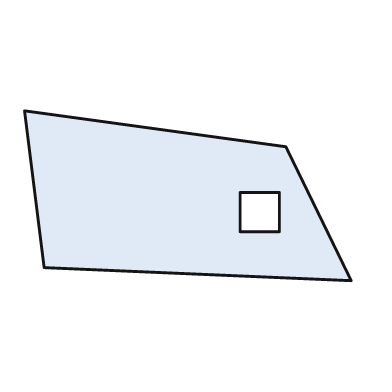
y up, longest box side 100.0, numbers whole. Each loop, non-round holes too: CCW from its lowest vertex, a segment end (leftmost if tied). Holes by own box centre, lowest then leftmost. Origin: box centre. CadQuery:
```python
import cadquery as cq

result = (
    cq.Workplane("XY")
    .moveTo(50.0, -26.0)
    .lineTo(30.0, 15.0)
    .lineTo(-50.0, 26.0)
    .lineTo(-44.0, -22.0)
    .close()
    .moveTo(16.0, -11.0)
    .lineTo(28.0, -11.0)
    .lineTo(28.0, 1.0)
    .lineTo(16.0, 1.0)
    .close()
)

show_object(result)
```